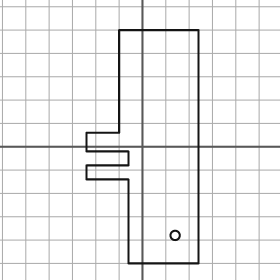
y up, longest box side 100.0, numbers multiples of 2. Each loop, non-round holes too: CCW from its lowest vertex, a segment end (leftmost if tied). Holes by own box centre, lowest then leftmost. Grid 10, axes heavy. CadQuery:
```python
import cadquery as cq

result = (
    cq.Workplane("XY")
    .moveTo(-6.0, -50.0)
    .lineTo(24.0, -50.0)
    .lineTo(24.0, 50.0)
    .lineTo(-10.0, 50.0)
    .lineTo(-10.0, 6.0)
    .lineTo(-24.0, 6.0)
    .lineTo(-24.0, -2.0)
    .lineTo(-6.0, -2.0)
    .lineTo(-6.0, -8.0)
    .lineTo(-24.0, -8.0)
    .lineTo(-24.0, -14.0)
    .lineTo(-6.0, -14.0)
    .close()
    .moveTo(14.0, -38.0)
    .circle(2.0)
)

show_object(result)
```